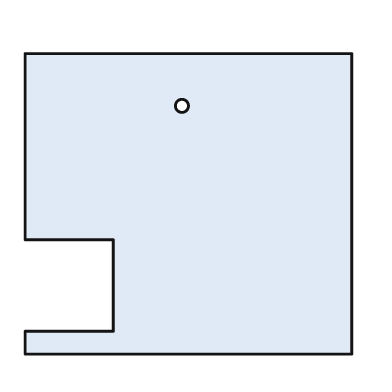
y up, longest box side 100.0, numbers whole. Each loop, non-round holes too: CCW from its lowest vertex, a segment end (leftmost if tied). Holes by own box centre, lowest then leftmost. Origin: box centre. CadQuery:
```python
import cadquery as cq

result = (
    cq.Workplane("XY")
    .moveTo(-50.0, -46.0)
    .lineTo(50.0, -46.0)
    .lineTo(50.0, 46.0)
    .lineTo(-50.0, 46.0)
    .lineTo(-50.0, -11.0)
    .lineTo(-23.0, -11.0)
    .lineTo(-23.0, -39.0)
    .lineTo(-50.0, -39.0)
    .close()
    .moveTo(-2.0, 30.0)
    .circle(2.0)
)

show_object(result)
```